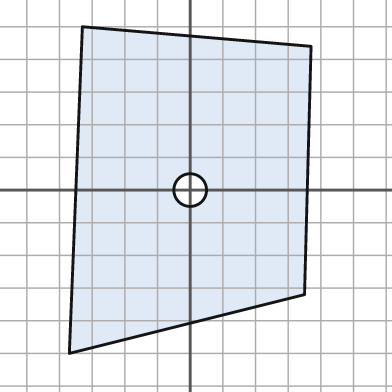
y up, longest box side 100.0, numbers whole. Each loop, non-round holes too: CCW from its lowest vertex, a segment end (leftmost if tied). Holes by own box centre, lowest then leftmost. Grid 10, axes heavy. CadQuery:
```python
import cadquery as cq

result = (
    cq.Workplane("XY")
    .moveTo(-37.0, -50.0)
    .lineTo(35.0, -32.0)
    .lineTo(37.0, 44.0)
    .lineTo(-33.0, 50.0)
    .close()
    .moveTo(0.0, 0.0)
    .circle(5.0)
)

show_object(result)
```